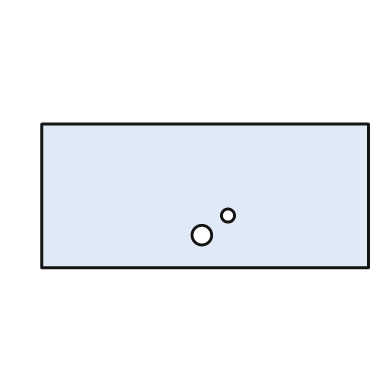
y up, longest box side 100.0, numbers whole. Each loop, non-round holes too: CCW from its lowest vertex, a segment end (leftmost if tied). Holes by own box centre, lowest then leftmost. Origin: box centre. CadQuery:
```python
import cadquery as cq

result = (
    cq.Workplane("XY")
    .moveTo(-50.0, -22.0)
    .lineTo(50.0, -22.0)
    .lineTo(50.0, 22.0)
    .lineTo(-50.0, 22.0)
    .close()
    .moveTo(-1.0, -12.0)
    .circle(3.0)
    .moveTo(7.0, -6.0)
    .circle(2.0)
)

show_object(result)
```